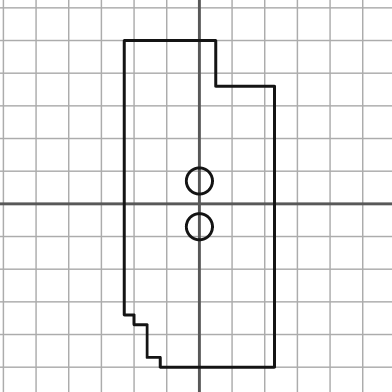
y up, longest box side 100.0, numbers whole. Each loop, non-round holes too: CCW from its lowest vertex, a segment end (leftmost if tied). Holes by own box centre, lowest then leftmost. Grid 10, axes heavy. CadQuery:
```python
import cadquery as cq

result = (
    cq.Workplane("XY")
    .moveTo(-12.0, -50.0)
    .lineTo(23.0, -50.0)
    .lineTo(23.0, 36.0)
    .lineTo(5.0, 36.0)
    .lineTo(5.0, 50.0)
    .lineTo(-23.0, 50.0)
    .lineTo(-23.0, -34.0)
    .lineTo(-20.0, -34.0)
    .lineTo(-20.0, -37.0)
    .lineTo(-16.0, -37.0)
    .lineTo(-16.0, -47.0)
    .lineTo(-12.0, -47.0)
    .close()
    .moveTo(0.0, -7.0)
    .circle(4.0)
    .moveTo(0.0, 7.0)
    .circle(4.0)
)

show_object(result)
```